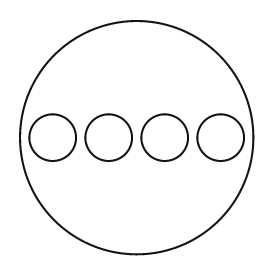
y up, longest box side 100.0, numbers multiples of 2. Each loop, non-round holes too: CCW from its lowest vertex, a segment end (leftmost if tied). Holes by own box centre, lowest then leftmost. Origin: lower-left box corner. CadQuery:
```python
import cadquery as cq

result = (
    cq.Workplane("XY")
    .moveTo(50.0, 50.0)
    .circle(50.0)
    .moveTo(14.0, 50.0)
    .circle(10.0)
    .moveTo(38.0, 50.0)
    .circle(10.0)
    .moveTo(62.0, 50.0)
    .circle(10.0)
    .moveTo(86.0, 50.0)
    .circle(10.0)
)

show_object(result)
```